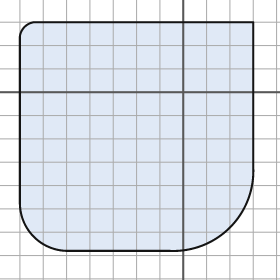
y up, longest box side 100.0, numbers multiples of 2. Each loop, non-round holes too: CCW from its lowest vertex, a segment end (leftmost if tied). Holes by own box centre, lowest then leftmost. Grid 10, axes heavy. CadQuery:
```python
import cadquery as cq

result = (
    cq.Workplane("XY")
    .moveTo(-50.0, -68.0)
    .lineTo(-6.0, -68.0)
    .threePointArc((20.0, -58.0), (30.0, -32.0))
    .lineTo(30.0, 30.0)
    .lineTo(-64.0, 30.0)
    .threePointArc((-68.0, 28.0), (-70.0, 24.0))
    .lineTo(-70.0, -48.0)
    .threePointArc((-64.0, -62.0), (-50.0, -68.0))
    .close()
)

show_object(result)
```